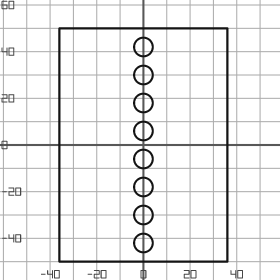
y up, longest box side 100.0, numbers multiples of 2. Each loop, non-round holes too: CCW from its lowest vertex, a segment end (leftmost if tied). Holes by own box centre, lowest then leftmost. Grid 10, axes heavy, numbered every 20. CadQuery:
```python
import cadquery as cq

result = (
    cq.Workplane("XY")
    .moveTo(-36.0, -50.0)
    .lineTo(36.0, -50.0)
    .lineTo(36.0, 50.0)
    .lineTo(-36.0, 50.0)
    .close()
    .moveTo(0.0, -42.0)
    .circle(4.0)
    .moveTo(0.0, -30.0)
    .circle(4.0)
    .moveTo(0.0, -18.0)
    .circle(4.0)
    .moveTo(0.0, -6.0)
    .circle(4.0)
    .moveTo(0.0, 6.0)
    .circle(4.0)
    .moveTo(0.0, 18.0)
    .circle(4.0)
    .moveTo(0.0, 30.0)
    .circle(4.0)
    .moveTo(0.0, 42.0)
    .circle(4.0)
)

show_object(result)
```